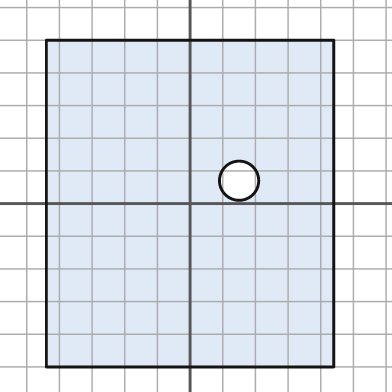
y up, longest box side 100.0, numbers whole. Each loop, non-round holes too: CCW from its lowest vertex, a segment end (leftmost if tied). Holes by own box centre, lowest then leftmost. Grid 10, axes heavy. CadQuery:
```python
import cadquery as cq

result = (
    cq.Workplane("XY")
    .moveTo(-44.0, -50.0)
    .lineTo(44.0, -50.0)
    .lineTo(44.0, 50.0)
    .lineTo(-44.0, 50.0)
    .close()
    .moveTo(15.0, 7.0)
    .circle(6.0)
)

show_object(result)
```